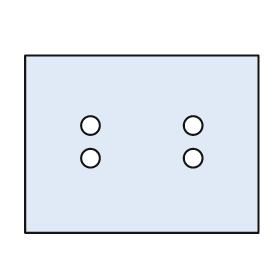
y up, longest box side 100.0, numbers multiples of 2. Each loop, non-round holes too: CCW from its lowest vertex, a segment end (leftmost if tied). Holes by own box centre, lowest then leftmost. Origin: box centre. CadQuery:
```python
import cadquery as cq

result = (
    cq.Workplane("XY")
    .moveTo(-50.0, -38.0)
    .lineTo(50.0, -38.0)
    .lineTo(50.0, 38.0)
    .lineTo(-50.0, 38.0)
    .close()
    .moveTo(-22.0, -6.0)
    .circle(4.0)
    .moveTo(22.0, -6.0)
    .circle(4.0)
    .moveTo(-22.0, 8.0)
    .circle(4.0)
    .moveTo(22.0, 8.0)
    .circle(4.0)
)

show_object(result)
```